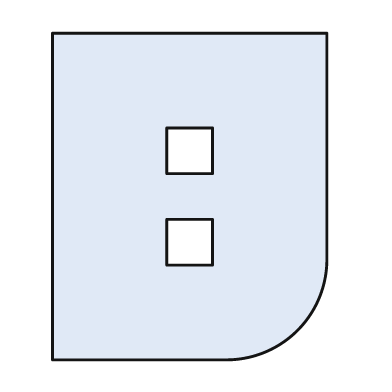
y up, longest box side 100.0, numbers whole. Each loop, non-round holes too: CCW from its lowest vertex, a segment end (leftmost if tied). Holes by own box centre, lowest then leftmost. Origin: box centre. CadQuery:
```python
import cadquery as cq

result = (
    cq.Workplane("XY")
    .moveTo(-42.0, -50.0)
    .lineTo(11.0, -50.0)
    .threePointArc((33.0, -41.0), (42.0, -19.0))
    .lineTo(42.0, 50.0)
    .lineTo(-42.0, 50.0)
    .close()
    .moveTo(-7.0, -21.0)
    .lineTo(7.0, -21.0)
    .lineTo(7.0, -7.0)
    .lineTo(-7.0, -7.0)
    .close()
    .moveTo(-7.0, 7.0)
    .lineTo(7.0, 7.0)
    .lineTo(7.0, 21.0)
    .lineTo(-7.0, 21.0)
    .close()
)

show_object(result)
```